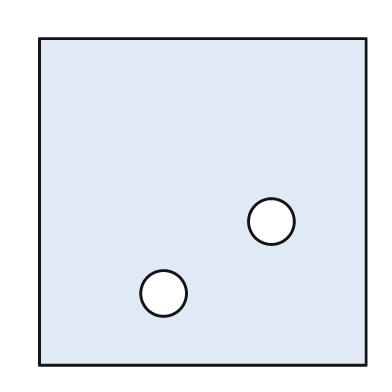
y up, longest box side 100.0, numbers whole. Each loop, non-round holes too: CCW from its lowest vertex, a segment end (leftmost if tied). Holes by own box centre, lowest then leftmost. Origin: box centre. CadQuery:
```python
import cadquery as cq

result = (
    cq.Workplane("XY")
    .moveTo(-50.0, -50.0)
    .lineTo(50.0, -50.0)
    .lineTo(50.0, 50.0)
    .lineTo(-50.0, 50.0)
    .close()
    .moveTo(-12.0, -28.0)
    .circle(7.0)
    .moveTo(21.0, -6.0)
    .circle(7.0)
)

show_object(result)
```